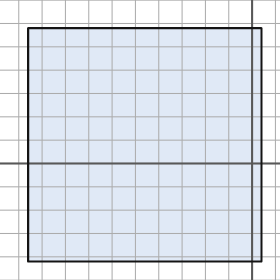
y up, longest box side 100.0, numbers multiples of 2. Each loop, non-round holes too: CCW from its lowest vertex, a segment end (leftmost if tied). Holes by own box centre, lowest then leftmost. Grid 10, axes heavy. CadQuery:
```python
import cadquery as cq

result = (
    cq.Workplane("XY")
    .moveTo(-96.0, -42.0)
    .lineTo(4.0, -42.0)
    .lineTo(4.0, 58.0)
    .lineTo(-96.0, 58.0)
    .close()
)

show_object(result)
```